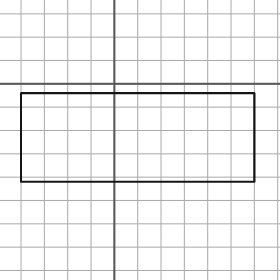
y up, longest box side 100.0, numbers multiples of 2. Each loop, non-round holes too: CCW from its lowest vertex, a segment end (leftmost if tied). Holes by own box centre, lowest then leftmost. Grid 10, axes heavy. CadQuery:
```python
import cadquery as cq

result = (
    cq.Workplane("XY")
    .moveTo(-40.0, -42.0)
    .lineTo(60.0, -42.0)
    .lineTo(60.0, -4.0)
    .lineTo(-40.0, -4.0)
    .close()
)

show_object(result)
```